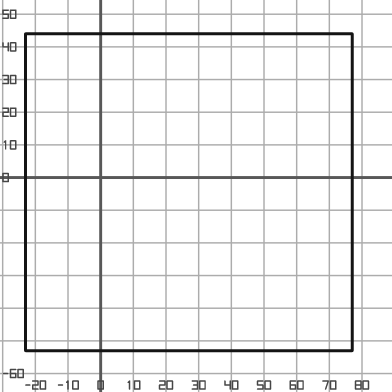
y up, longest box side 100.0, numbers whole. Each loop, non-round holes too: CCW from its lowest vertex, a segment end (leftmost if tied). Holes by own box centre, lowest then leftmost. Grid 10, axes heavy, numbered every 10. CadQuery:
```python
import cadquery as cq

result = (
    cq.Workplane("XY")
    .moveTo(-23.0, -53.0)
    .lineTo(77.0, -53.0)
    .lineTo(77.0, 44.0)
    .lineTo(-23.0, 44.0)
    .close()
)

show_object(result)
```